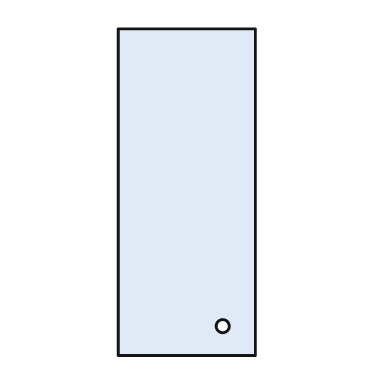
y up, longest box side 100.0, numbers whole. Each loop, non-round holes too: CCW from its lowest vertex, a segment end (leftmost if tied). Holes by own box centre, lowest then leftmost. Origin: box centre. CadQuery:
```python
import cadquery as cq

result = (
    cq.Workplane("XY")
    .moveTo(-21.0, -50.0)
    .lineTo(21.0, -50.0)
    .lineTo(21.0, 50.0)
    .lineTo(-21.0, 50.0)
    .close()
    .moveTo(11.0, -41.0)
    .circle(2.0)
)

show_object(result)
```